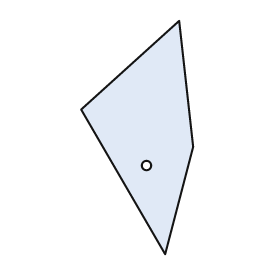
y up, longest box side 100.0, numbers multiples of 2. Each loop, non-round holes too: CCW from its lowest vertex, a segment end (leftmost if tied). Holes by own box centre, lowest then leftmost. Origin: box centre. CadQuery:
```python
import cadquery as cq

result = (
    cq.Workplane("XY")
    .moveTo(12.0, -50.0)
    .lineTo(24.0, -4.0)
    .lineTo(18.0, 50.0)
    .lineTo(-24.0, 12.0)
    .close()
    .moveTo(4.0, -12.0)
    .circle(2.0)
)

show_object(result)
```